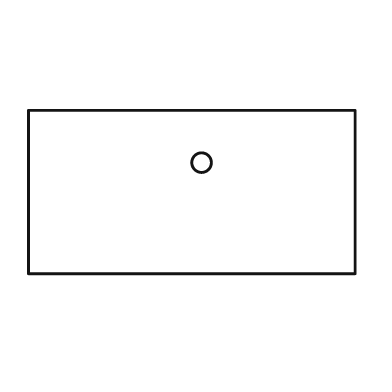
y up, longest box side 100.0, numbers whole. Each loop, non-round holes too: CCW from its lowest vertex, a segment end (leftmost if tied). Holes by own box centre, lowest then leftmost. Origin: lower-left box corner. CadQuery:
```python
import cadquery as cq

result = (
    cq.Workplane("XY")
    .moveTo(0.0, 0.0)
    .lineTo(100.0, 0.0)
    .lineTo(100.0, 50.0)
    .lineTo(0.0, 50.0)
    .close()
    .moveTo(53.0, 34.0)
    .circle(3.0)
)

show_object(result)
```